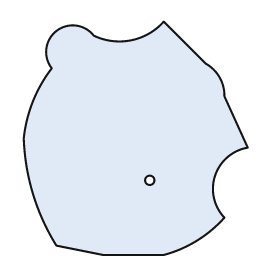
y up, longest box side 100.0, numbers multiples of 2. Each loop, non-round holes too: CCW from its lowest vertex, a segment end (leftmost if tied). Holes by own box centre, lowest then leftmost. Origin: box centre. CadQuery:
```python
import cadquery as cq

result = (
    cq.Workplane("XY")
    .moveTo(-14.0, -50.0)
    .lineTo(12.0, -50.0)
    .threePointArc((26.0, -44.0), (38.0, -34.0))
    .threePointArc((34.0, -16.0), (48.0, -4.0))
    .lineTo(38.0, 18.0)
    .threePointArc((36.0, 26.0), (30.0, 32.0))
    .lineTo(12.0, 50.0)
    .threePointArc((-2.0, 42.0), (-18.0, 44.0))
    .threePointArc((-34.0, 46.0), (-36.0, 30.0))
    .threePointArc((-44.0, 16.0), (-48.0, 0.0))
    .threePointArc((-44.0, -24.0), (-34.0, -46.0))
    .close()
    .moveTo(6.0, -18.0)
    .circle(2.0)
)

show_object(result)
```